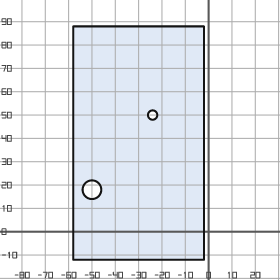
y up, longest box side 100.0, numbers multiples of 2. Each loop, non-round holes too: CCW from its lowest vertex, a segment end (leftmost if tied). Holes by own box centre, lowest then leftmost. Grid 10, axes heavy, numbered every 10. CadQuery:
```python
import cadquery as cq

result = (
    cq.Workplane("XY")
    .moveTo(-58.0, -12.0)
    .lineTo(-2.0, -12.0)
    .lineTo(-2.0, 88.0)
    .lineTo(-58.0, 88.0)
    .close()
    .moveTo(-50.0, 18.0)
    .circle(4.0)
    .moveTo(-24.0, 50.0)
    .circle(2.0)
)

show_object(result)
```